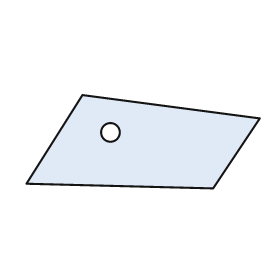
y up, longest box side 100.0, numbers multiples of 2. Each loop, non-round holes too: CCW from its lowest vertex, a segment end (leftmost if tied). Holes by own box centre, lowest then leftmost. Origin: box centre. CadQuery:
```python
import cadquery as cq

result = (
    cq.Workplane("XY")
    .moveTo(30.0, -20.0)
    .lineTo(50.0, 10.0)
    .lineTo(-26.0, 20.0)
    .lineTo(-50.0, -18.0)
    .close()
    .moveTo(-14.0, 4.0)
    .circle(4.0)
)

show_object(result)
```